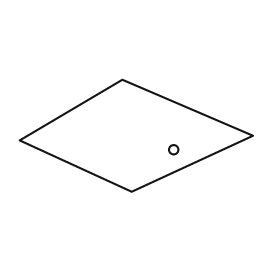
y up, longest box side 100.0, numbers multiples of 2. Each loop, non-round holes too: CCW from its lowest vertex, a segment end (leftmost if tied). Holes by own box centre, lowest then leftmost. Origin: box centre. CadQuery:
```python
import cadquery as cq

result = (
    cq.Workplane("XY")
    .moveTo(-2.0, -24.0)
    .lineTo(50.0, 0.0)
    .lineTo(-6.0, 24.0)
    .lineTo(-50.0, -2.0)
    .close()
    .moveTo(16.0, -6.0)
    .circle(2.0)
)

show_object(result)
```